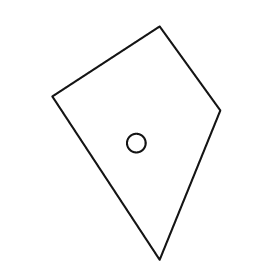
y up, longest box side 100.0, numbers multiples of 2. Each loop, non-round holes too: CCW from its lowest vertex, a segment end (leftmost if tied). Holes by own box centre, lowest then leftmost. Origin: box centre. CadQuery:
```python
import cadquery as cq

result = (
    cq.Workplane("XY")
    .moveTo(10.0, -50.0)
    .lineTo(36.0, 14.0)
    .lineTo(10.0, 50.0)
    .lineTo(-36.0, 20.0)
    .close()
    .moveTo(0.0, 0.0)
    .circle(4.0)
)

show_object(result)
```